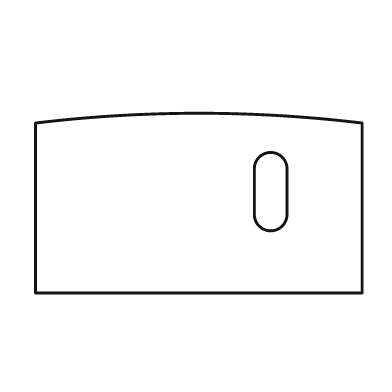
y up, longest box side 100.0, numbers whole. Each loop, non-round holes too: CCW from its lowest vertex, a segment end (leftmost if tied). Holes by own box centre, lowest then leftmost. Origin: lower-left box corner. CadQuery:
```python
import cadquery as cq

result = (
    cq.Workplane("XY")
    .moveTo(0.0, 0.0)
    .lineTo(100.0, 0.0)
    .lineTo(100.0, 52.0)
    .threePointArc((50.0, 55.0), (0.0, 52.0))
    .close()
    .moveTo(67.0, 24.0)
    .threePointArc((72.0, 19.0), (77.0, 24.0))
    .lineTo(77.0, 38.0)
    .threePointArc((72.0, 43.0), (67.0, 38.0))
    .close()
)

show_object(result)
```